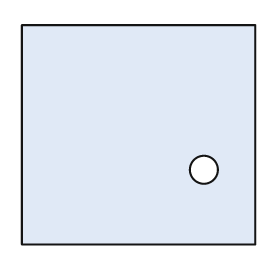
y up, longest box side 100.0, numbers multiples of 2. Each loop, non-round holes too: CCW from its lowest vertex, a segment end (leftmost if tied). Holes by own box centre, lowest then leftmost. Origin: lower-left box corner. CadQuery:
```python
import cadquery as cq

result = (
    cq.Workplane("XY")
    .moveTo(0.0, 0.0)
    .lineTo(100.0, 0.0)
    .lineTo(100.0, 94.0)
    .lineTo(0.0, 94.0)
    .close()
    .moveTo(78.0, 32.0)
    .circle(6.0)
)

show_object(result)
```